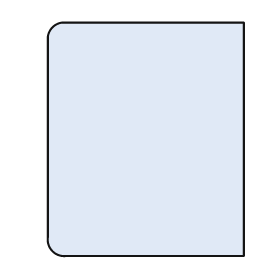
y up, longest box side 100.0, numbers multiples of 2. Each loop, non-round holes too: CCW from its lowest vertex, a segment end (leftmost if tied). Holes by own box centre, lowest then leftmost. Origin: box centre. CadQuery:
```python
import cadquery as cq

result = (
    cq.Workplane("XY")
    .moveTo(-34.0, -50.0)
    .lineTo(42.0, -50.0)
    .lineTo(42.0, 50.0)
    .lineTo(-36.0, 50.0)
    .threePointArc((-40.0, 48.0), (-42.0, 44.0))
    .lineTo(-42.0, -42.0)
    .threePointArc((-40.0, -48.0), (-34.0, -50.0))
    .close()
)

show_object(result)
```